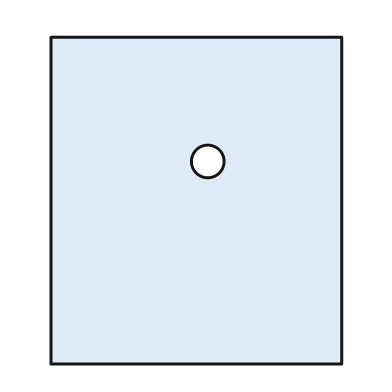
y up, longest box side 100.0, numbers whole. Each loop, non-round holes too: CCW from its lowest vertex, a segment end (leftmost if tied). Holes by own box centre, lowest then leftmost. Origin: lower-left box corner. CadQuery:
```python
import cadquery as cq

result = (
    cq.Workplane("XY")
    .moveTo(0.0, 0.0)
    .lineTo(89.0, 0.0)
    .lineTo(89.0, 100.0)
    .lineTo(0.0, 100.0)
    .close()
    .moveTo(48.0, 62.0)
    .circle(5.0)
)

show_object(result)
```